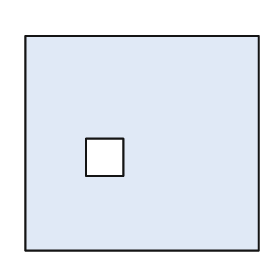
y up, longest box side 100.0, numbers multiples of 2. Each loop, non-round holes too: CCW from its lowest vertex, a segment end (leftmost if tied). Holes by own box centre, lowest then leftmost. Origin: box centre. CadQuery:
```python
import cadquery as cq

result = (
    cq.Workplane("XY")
    .moveTo(-50.0, -46.0)
    .lineTo(50.0, -46.0)
    .lineTo(50.0, 46.0)
    .lineTo(-50.0, 46.0)
    .close()
    .moveTo(-24.0, -14.0)
    .lineTo(-8.0, -14.0)
    .lineTo(-8.0, 2.0)
    .lineTo(-24.0, 2.0)
    .close()
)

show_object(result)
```